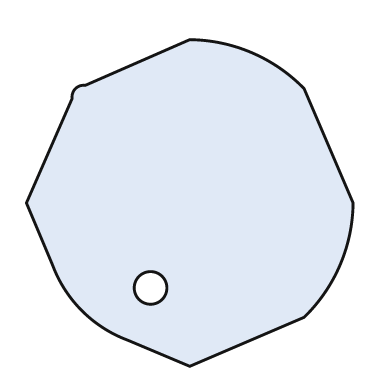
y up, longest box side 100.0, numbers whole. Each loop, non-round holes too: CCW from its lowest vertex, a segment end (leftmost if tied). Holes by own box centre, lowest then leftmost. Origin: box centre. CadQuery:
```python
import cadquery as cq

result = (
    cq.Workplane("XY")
    .moveTo(0.0, -50.0)
    .lineTo(35.0, -35.0)
    .threePointArc((46.0, -19.0), (50.0, 0.0))
    .lineTo(35.0, 35.0)
    .threePointArc((19.0, 46.0), (0.0, 50.0))
    .lineTo(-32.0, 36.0)
    .threePointArc((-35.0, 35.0), (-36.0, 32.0))
    .lineTo(-50.0, 0.0)
    .lineTo(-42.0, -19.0)
    .threePointArc((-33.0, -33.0), (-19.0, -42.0))
    .close()
    .moveTo(-12.0, -26.0)
    .circle(5.0)
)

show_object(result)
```